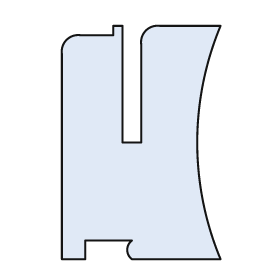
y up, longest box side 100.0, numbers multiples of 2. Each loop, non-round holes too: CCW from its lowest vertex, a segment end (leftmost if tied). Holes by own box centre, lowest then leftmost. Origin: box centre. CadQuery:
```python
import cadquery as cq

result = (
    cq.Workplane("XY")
    .moveTo(-34.0, -50.0)
    .lineTo(-24.0, -50.0)
    .lineTo(-24.0, -42.0)
    .lineTo(-4.0, -42.0)
    .threePointArc((-6.0, -46.0), (-4.0, -50.0))
    .lineTo(34.0, -50.0)
    .threePointArc((24.0, 0.0), (34.0, 50.0))
    .lineTo(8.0, 50.0)
    .threePointArc((2.0, 48.0), (0.0, 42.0))
    .lineTo(0.0, 0.0)
    .lineTo(-8.0, 0.0)
    .lineTo(-8.0, 50.0)
    .lineTo(-12.0, 50.0)
    .lineTo(-12.0, 46.0)
    .lineTo(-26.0, 46.0)
    .threePointArc((-32.0, 44.0), (-34.0, 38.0))
    .close()
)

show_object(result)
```